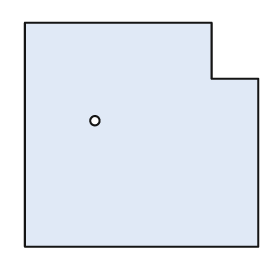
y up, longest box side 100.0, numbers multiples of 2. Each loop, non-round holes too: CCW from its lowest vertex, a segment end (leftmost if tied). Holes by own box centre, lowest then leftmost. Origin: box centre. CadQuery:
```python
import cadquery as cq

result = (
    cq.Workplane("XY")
    .moveTo(-50.0, -48.0)
    .lineTo(50.0, -48.0)
    .lineTo(50.0, 24.0)
    .lineTo(30.0, 24.0)
    .lineTo(30.0, 48.0)
    .lineTo(-50.0, 48.0)
    .close()
    .moveTo(-20.0, 6.0)
    .circle(2.0)
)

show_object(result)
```